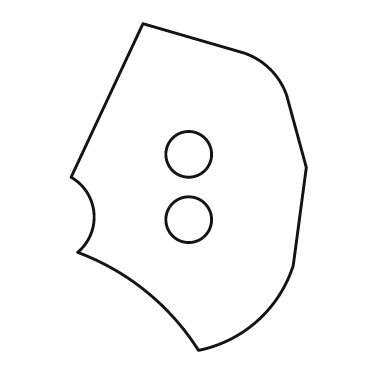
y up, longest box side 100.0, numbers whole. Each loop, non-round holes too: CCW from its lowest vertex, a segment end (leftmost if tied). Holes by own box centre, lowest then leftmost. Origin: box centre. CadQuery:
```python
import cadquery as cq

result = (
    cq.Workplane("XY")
    .moveTo(3.0, -50.0)
    .threePointArc((21.0, -41.0), (32.0, -24.0))
    .lineTo(36.0, 6.0)
    .lineTo(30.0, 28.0)
    .threePointArc((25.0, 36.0), (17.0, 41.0))
    .lineTo(-14.0, 50.0)
    .lineTo(-36.0, 3.0)
    .threePointArc((-29.0, -8.0), (-34.0, -20.0))
    .threePointArc((-13.0, -32.0), (3.0, -50.0))
    .close()
    .moveTo(0.0, -10.0)
    .circle(7.0)
    .moveTo(0.0, 10.0)
    .circle(7.0)
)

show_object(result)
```